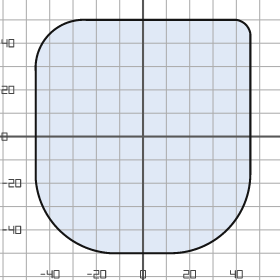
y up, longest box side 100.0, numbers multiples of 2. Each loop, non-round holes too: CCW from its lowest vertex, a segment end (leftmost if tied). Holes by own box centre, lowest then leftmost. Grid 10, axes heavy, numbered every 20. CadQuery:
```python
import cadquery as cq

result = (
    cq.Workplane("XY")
    .moveTo(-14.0, -50.0)
    .lineTo(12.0, -50.0)
    .threePointArc((36.0, -40.0), (46.0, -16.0))
    .lineTo(46.0, 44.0)
    .threePointArc((44.0, 48.0), (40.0, 50.0))
    .lineTo(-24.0, 50.0)
    .threePointArc((-40.0, 44.0), (-46.0, 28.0))
    .lineTo(-46.0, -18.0)
    .threePointArc((-36.0, -40.0), (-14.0, -50.0))
    .close()
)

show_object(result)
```